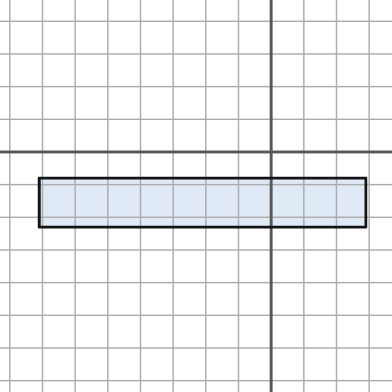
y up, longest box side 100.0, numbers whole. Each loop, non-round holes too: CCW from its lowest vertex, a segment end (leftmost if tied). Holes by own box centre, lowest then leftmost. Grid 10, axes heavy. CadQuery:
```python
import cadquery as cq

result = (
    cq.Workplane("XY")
    .moveTo(-71.0, -23.0)
    .lineTo(29.0, -23.0)
    .lineTo(29.0, -8.0)
    .lineTo(-71.0, -8.0)
    .close()
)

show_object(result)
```